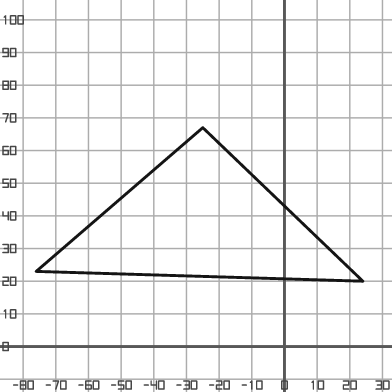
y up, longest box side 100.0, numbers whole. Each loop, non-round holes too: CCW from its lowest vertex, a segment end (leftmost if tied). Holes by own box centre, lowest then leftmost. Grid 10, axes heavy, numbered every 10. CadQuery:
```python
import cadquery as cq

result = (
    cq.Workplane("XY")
    .moveTo(24.0, 20.0)
    .lineTo(-25.0, 67.0)
    .lineTo(-76.0, 23.0)
    .close()
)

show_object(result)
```